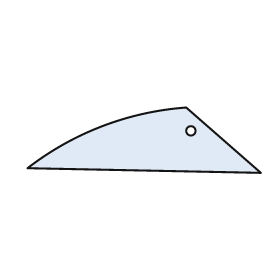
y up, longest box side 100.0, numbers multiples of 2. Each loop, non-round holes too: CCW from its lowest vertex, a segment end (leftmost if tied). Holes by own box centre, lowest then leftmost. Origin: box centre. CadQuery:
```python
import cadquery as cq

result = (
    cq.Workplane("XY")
    .moveTo(50.0, -14.0)
    .lineTo(18.0, 14.0)
    .threePointArc((-18.0, 6.0), (-50.0, -12.0))
    .close()
    .moveTo(20.0, 4.0)
    .circle(2.0)
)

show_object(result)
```